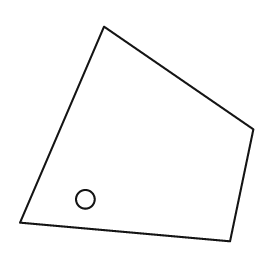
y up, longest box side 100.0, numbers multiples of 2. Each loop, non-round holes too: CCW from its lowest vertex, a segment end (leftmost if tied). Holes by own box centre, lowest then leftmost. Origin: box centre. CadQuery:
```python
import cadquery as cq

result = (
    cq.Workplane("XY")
    .moveTo(40.0, -46.0)
    .lineTo(50.0, 2.0)
    .lineTo(-14.0, 46.0)
    .lineTo(-50.0, -38.0)
    .close()
    .moveTo(-22.0, -28.0)
    .circle(4.0)
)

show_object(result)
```